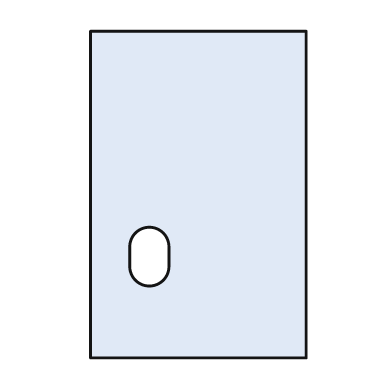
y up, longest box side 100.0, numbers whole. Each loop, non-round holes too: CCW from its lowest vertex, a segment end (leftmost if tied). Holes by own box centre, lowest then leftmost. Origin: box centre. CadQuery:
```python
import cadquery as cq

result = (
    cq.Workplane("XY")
    .moveTo(-33.0, -50.0)
    .lineTo(33.0, -50.0)
    .lineTo(33.0, 50.0)
    .lineTo(-33.0, 50.0)
    .close()
    .moveTo(-21.0, -22.0)
    .threePointArc((-15.0, -28.0), (-9.0, -22.0))
    .lineTo(-9.0, -16.0)
    .threePointArc((-15.0, -10.0), (-21.0, -16.0))
    .close()
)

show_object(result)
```